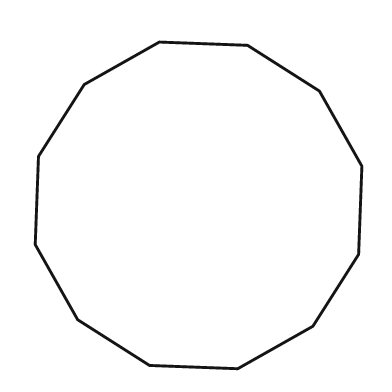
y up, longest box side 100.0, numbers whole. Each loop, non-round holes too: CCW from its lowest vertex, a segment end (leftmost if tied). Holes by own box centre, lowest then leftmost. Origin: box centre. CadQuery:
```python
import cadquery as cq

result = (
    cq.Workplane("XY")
    .moveTo(12.0, -50.0)
    .lineTo(35.0, -37.0)
    .lineTo(49.0, -15.0)
    .lineTo(50.0, 12.0)
    .lineTo(37.0, 35.0)
    .lineTo(15.0, 49.0)
    .lineTo(-12.0, 50.0)
    .lineTo(-35.0, 37.0)
    .lineTo(-49.0, 15.0)
    .lineTo(-50.0, -12.0)
    .lineTo(-37.0, -35.0)
    .lineTo(-15.0, -49.0)
    .close()
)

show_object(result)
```